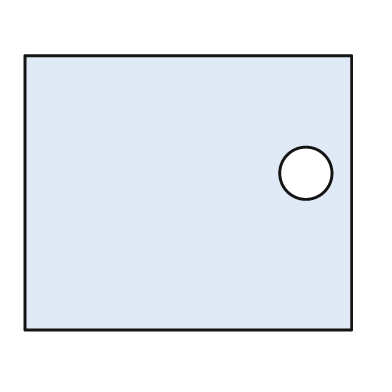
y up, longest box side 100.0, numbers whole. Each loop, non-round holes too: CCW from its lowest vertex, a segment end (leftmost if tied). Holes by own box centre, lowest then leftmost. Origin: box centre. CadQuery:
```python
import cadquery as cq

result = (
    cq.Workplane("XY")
    .moveTo(-50.0, -42.0)
    .lineTo(50.0, -42.0)
    .lineTo(50.0, 42.0)
    .lineTo(-50.0, 42.0)
    .close()
    .moveTo(36.0, 6.0)
    .circle(8.0)
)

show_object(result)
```